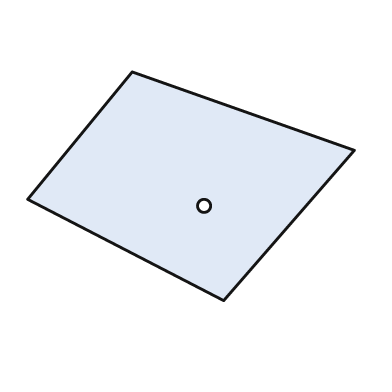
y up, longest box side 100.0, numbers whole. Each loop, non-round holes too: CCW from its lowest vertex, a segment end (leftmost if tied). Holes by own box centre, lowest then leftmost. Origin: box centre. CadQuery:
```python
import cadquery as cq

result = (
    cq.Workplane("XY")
    .moveTo(10.0, -35.0)
    .lineTo(50.0, 11.0)
    .lineTo(-18.0, 35.0)
    .lineTo(-50.0, -4.0)
    .close()
    .moveTo(4.0, -6.0)
    .circle(2.0)
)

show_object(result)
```